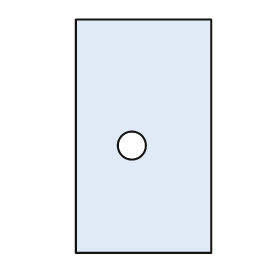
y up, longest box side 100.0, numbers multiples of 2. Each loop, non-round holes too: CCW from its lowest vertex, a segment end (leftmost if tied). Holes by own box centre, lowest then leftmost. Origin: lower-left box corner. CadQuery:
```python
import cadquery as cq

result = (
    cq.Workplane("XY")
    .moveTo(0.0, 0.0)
    .lineTo(58.0, 0.0)
    .lineTo(58.0, 100.0)
    .lineTo(0.0, 100.0)
    .close()
    .moveTo(24.0, 46.0)
    .circle(6.0)
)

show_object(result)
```